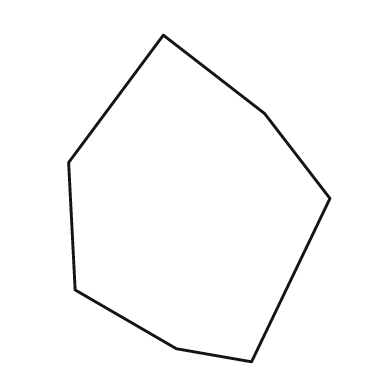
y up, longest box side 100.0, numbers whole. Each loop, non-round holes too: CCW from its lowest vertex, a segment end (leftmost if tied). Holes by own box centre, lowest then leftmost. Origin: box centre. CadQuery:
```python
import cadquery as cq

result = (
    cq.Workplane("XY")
    .moveTo(16.0, -50.0)
    .lineTo(40.0, 0.0)
    .lineTo(20.0, 26.0)
    .lineTo(-11.0, 50.0)
    .lineTo(-40.0, 11.0)
    .lineTo(-38.0, -28.0)
    .lineTo(-7.0, -46.0)
    .close()
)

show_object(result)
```